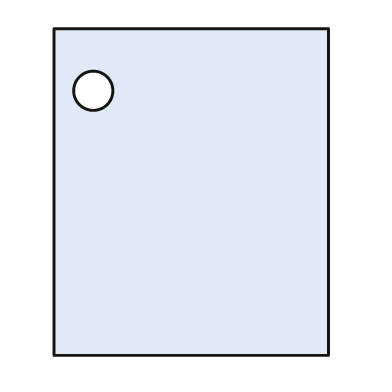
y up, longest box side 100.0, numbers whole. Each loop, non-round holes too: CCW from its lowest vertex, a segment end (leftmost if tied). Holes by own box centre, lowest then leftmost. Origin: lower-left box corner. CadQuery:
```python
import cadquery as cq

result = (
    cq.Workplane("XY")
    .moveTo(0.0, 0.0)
    .lineTo(84.0, 0.0)
    .lineTo(84.0, 100.0)
    .lineTo(0.0, 100.0)
    .close()
    .moveTo(12.0, 81.0)
    .circle(6.0)
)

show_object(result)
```